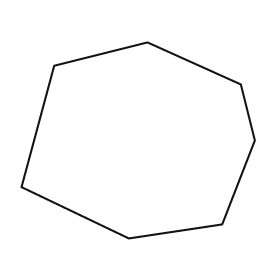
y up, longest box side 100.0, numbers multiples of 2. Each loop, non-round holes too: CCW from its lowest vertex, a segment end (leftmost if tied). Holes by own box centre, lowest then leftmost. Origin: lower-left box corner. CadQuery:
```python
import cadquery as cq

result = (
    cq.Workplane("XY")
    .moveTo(46.0, 0.0)
    .lineTo(86.0, 6.0)
    .lineTo(100.0, 42.0)
    .lineTo(94.0, 66.0)
    .lineTo(54.0, 84.0)
    .lineTo(14.0, 74.0)
    .lineTo(0.0, 22.0)
    .close()
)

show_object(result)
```